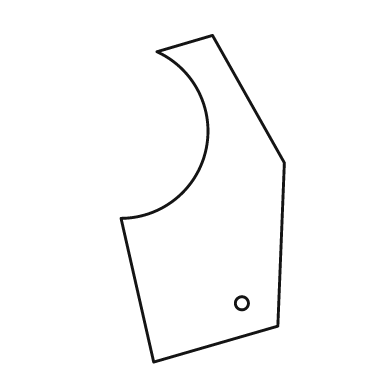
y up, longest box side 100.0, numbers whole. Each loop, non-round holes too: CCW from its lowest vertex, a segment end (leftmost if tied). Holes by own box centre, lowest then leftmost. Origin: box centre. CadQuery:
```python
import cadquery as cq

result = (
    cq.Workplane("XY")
    .moveTo(-15.0, -50.0)
    .lineTo(23.0, -39.0)
    .lineTo(25.0, 11.0)
    .lineTo(3.0, 50.0)
    .lineTo(-14.0, 45.0)
    .threePointArc((1.0, 15.0), (-25.0, -6.0))
    .close()
    .moveTo(12.0, -32.0)
    .circle(2.0)
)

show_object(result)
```